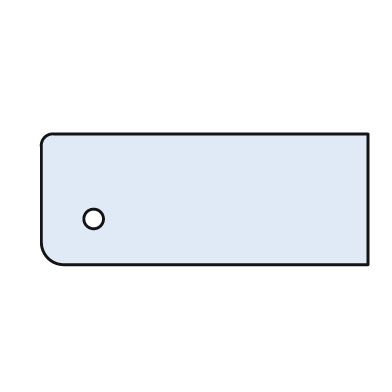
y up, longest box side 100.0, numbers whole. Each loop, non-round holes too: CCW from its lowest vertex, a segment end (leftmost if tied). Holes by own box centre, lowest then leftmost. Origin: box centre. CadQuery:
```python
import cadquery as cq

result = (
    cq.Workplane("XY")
    .moveTo(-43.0, -20.0)
    .lineTo(50.0, -20.0)
    .lineTo(50.0, 20.0)
    .lineTo(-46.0, 20.0)
    .threePointArc((-49.0, 19.0), (-50.0, 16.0))
    .lineTo(-50.0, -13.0)
    .threePointArc((-48.0, -18.0), (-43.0, -20.0))
    .close()
    .moveTo(-34.0, -6.0)
    .circle(3.0)
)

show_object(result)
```